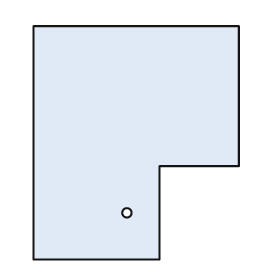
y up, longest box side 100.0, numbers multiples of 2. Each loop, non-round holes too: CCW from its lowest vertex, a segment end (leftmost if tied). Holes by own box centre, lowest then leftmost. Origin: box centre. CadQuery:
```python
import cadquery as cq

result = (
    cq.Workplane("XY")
    .moveTo(-44.0, -50.0)
    .lineTo(10.0, -50.0)
    .lineTo(10.0, -10.0)
    .lineTo(44.0, -10.0)
    .lineTo(44.0, 50.0)
    .lineTo(-44.0, 50.0)
    .close()
    .moveTo(-4.0, -30.0)
    .circle(2.0)
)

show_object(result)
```